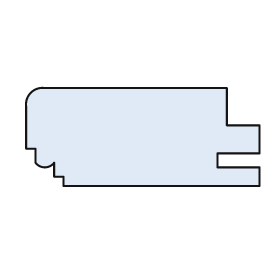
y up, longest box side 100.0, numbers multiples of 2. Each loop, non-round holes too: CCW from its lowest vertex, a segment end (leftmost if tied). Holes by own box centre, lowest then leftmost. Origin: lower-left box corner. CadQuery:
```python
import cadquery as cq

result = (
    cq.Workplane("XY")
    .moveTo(16.0, 0.0)
    .lineTo(100.0, 0.0)
    .lineTo(100.0, 8.0)
    .lineTo(82.0, 8.0)
    .lineTo(82.0, 14.0)
    .lineTo(100.0, 14.0)
    .lineTo(100.0, 26.0)
    .lineTo(86.0, 26.0)
    .lineTo(86.0, 42.0)
    .lineTo(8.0, 42.0)
    .threePointArc((2.0, 40.0), (0.0, 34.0))
    .lineTo(0.0, 16.0)
    .lineTo(4.0, 16.0)
    .lineTo(4.0, 10.0)
    .threePointArc((8.0, 8.0), (12.0, 10.0))
    .lineTo(12.0, 4.0)
    .lineTo(16.0, 4.0)
    .close()
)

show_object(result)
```